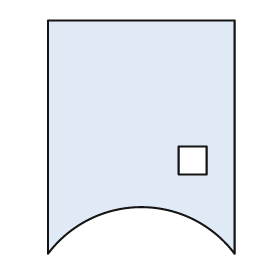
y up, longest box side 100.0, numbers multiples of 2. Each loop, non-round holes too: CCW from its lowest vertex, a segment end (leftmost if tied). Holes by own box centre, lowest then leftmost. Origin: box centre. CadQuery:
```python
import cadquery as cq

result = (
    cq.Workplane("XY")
    .moveTo(-40.0, -50.0)
    .threePointArc((0.0, -30.0), (40.0, -50.0))
    .lineTo(40.0, 50.0)
    .lineTo(-40.0, 50.0)
    .close()
    .moveTo(16.0, -16.0)
    .lineTo(28.0, -16.0)
    .lineTo(28.0, -4.0)
    .lineTo(16.0, -4.0)
    .close()
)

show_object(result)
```